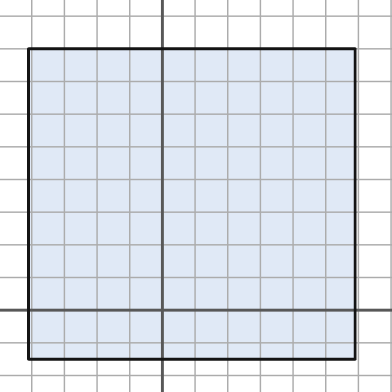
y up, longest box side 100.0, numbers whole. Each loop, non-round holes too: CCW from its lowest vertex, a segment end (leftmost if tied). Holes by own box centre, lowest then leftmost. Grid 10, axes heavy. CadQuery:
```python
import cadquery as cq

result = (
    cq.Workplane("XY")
    .moveTo(-41.0, -15.0)
    .lineTo(59.0, -15.0)
    .lineTo(59.0, 80.0)
    .lineTo(-41.0, 80.0)
    .close()
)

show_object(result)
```